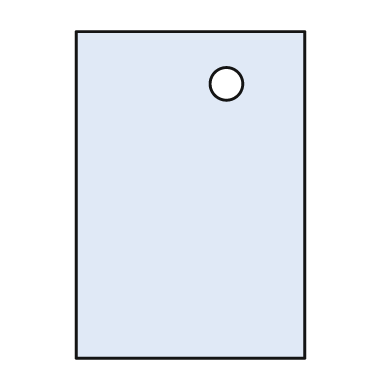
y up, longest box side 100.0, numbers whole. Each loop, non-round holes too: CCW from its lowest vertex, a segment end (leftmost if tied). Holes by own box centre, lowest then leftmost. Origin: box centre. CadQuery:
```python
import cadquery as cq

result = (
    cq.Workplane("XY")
    .moveTo(-35.0, -50.0)
    .lineTo(35.0, -50.0)
    .lineTo(35.0, 50.0)
    .lineTo(-35.0, 50.0)
    .close()
    .moveTo(11.0, 34.0)
    .circle(5.0)
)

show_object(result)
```